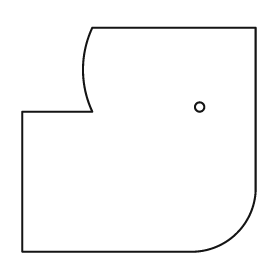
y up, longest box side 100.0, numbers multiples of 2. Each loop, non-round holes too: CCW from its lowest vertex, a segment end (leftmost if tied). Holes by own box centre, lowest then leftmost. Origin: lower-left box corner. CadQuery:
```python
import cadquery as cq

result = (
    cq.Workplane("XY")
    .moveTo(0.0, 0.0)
    .lineTo(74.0, 0.0)
    .threePointArc((92.0, 8.0), (100.0, 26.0))
    .lineTo(100.0, 96.0)
    .lineTo(30.0, 96.0)
    .threePointArc((26.0, 78.0), (30.0, 60.0))
    .lineTo(0.0, 60.0)
    .close()
    .moveTo(76.0, 62.0)
    .circle(2.0)
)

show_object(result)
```